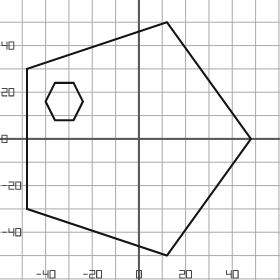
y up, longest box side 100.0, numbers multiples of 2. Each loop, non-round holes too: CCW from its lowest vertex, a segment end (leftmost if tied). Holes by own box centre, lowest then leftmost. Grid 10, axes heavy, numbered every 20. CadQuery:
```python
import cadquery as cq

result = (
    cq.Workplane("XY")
    .moveTo(12.0, -50.0)
    .lineTo(48.0, 0.0)
    .lineTo(12.0, 50.0)
    .lineTo(-48.0, 30.0)
    .lineTo(-48.0, -30.0)
    .close()
    .moveTo(-36.0, 8.0)
    .lineTo(-28.0, 8.0)
    .lineTo(-24.0, 16.0)
    .lineTo(-28.0, 24.0)
    .lineTo(-36.0, 24.0)
    .lineTo(-40.0, 16.0)
    .close()
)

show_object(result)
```